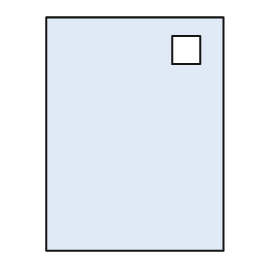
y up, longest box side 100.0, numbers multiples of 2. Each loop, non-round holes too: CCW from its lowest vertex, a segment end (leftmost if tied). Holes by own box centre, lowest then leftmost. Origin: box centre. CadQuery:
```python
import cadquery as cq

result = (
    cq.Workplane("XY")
    .moveTo(-38.0, -50.0)
    .lineTo(38.0, -50.0)
    .lineTo(38.0, 50.0)
    .lineTo(-38.0, 50.0)
    .close()
    .moveTo(16.0, 30.0)
    .lineTo(28.0, 30.0)
    .lineTo(28.0, 42.0)
    .lineTo(16.0, 42.0)
    .close()
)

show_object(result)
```